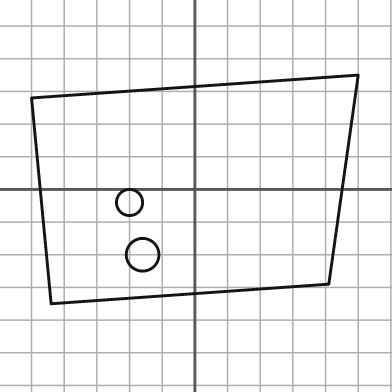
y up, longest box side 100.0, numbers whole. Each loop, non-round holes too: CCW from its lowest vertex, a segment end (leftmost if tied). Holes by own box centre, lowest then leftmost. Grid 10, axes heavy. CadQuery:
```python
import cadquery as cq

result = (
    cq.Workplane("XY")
    .moveTo(-44.0, -35.0)
    .lineTo(41.0, -29.0)
    .lineTo(50.0, 35.0)
    .lineTo(-50.0, 28.0)
    .close()
    .moveTo(-16.0, -20.0)
    .circle(5.0)
    .moveTo(-20.0, -4.0)
    .circle(4.0)
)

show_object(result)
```